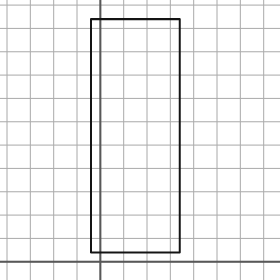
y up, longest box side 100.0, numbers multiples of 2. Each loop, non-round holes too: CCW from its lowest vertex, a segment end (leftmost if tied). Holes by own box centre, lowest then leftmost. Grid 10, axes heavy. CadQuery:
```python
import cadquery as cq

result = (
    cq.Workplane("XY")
    .moveTo(-4.0, 4.0)
    .lineTo(34.0, 4.0)
    .lineTo(34.0, 104.0)
    .lineTo(-4.0, 104.0)
    .close()
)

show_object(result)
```